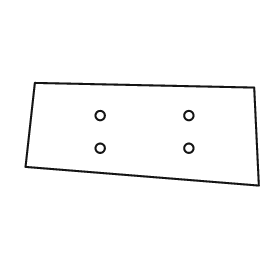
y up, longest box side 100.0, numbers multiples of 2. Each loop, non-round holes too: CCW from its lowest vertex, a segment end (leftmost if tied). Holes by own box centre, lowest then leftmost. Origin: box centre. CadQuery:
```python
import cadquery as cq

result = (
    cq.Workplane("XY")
    .moveTo(50.0, -22.0)
    .lineTo(48.0, 20.0)
    .lineTo(-46.0, 22.0)
    .lineTo(-50.0, -14.0)
    .close()
    .moveTo(-18.0, -6.0)
    .circle(2.0)
    .moveTo(20.0, -6.0)
    .circle(2.0)
    .moveTo(-18.0, 8.0)
    .circle(2.0)
    .moveTo(20.0, 8.0)
    .circle(2.0)
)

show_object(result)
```